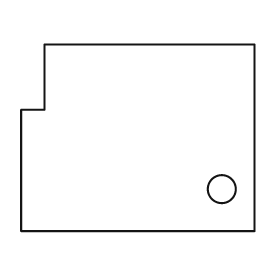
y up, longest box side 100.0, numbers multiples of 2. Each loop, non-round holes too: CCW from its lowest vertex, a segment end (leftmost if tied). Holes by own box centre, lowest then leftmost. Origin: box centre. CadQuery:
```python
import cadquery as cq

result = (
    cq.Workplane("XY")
    .moveTo(-50.0, -40.0)
    .lineTo(50.0, -40.0)
    .lineTo(50.0, 40.0)
    .lineTo(-40.0, 40.0)
    .lineTo(-40.0, 12.0)
    .lineTo(-50.0, 12.0)
    .close()
    .moveTo(36.0, -22.0)
    .circle(6.0)
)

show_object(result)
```